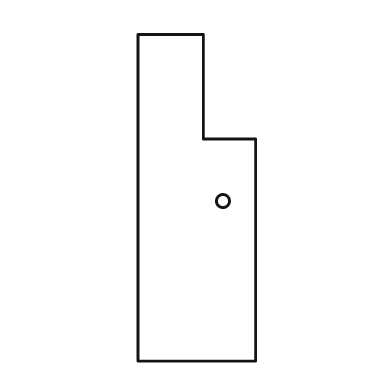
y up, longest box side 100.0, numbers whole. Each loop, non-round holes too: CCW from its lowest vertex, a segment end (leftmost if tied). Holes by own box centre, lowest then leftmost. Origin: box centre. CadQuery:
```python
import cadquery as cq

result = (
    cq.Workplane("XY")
    .moveTo(-18.0, -50.0)
    .lineTo(18.0, -50.0)
    .lineTo(18.0, 18.0)
    .lineTo(2.0, 18.0)
    .lineTo(2.0, 50.0)
    .lineTo(-18.0, 50.0)
    .close()
    .moveTo(8.0, -1.0)
    .circle(2.0)
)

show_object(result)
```